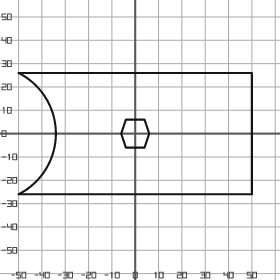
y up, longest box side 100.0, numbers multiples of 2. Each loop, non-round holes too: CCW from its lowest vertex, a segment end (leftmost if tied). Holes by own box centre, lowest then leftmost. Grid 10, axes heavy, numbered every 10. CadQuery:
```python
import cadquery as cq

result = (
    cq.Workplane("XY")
    .moveTo(-50.0, -26.0)
    .lineTo(50.0, -26.0)
    .lineTo(50.0, 26.0)
    .lineTo(-50.0, 26.0)
    .threePointArc((-34.0, 0.0), (-50.0, -26.0))
    .close()
    .moveTo(-4.0, -6.0)
    .lineTo(4.0, -6.0)
    .lineTo(6.0, 0.0)
    .lineTo(4.0, 6.0)
    .lineTo(-4.0, 6.0)
    .lineTo(-6.0, 0.0)
    .close()
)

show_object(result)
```